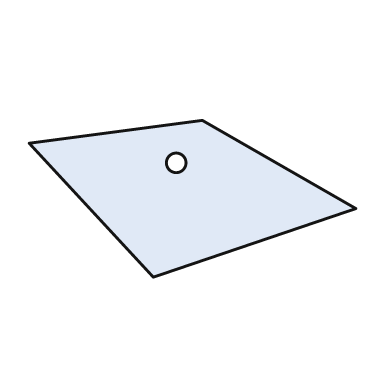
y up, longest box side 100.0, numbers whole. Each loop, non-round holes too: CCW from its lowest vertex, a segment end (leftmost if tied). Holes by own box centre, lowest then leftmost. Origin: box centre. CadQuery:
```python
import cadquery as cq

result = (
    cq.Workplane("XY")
    .moveTo(-12.0, -24.0)
    .lineTo(50.0, -3.0)
    .lineTo(3.0, 24.0)
    .lineTo(-50.0, 17.0)
    .close()
    .moveTo(-5.0, 11.0)
    .circle(3.0)
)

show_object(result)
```